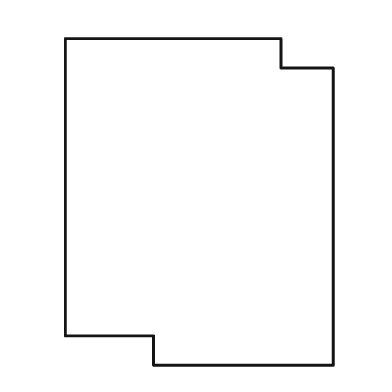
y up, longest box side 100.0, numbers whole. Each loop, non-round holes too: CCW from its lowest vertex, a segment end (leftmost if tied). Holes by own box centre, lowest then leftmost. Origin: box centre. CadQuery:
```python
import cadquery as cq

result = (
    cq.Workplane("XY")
    .moveTo(-14.0, -50.0)
    .lineTo(41.0, -50.0)
    .lineTo(41.0, 41.0)
    .lineTo(25.0, 41.0)
    .lineTo(25.0, 50.0)
    .lineTo(-41.0, 50.0)
    .lineTo(-41.0, -41.0)
    .lineTo(-14.0, -41.0)
    .close()
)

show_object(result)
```